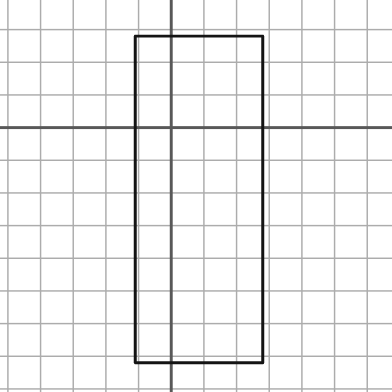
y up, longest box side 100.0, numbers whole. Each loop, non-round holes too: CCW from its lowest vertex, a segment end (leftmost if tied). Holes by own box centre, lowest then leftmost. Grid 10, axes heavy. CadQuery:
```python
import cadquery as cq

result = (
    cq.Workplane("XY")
    .moveTo(-11.0, -72.0)
    .lineTo(28.0, -72.0)
    .lineTo(28.0, 28.0)
    .lineTo(-11.0, 28.0)
    .close()
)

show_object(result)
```